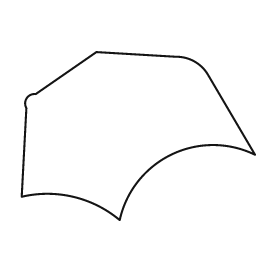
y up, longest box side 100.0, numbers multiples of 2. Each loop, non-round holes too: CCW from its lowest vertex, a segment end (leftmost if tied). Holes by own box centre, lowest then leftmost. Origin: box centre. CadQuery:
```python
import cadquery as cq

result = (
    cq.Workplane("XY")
    .moveTo(-8.0, -36.0)
    .threePointArc((14.0, -8.0), (50.0, -8.0))
    .lineTo(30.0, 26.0)
    .threePointArc((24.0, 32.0), (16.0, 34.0))
    .lineTo(-18.0, 36.0)
    .lineTo(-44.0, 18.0)
    .threePointArc((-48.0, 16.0), (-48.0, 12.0))
    .lineTo(-50.0, -26.0)
    .threePointArc((-28.0, -26.0), (-8.0, -36.0))
    .close()
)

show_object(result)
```